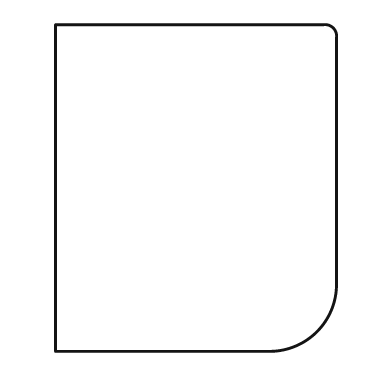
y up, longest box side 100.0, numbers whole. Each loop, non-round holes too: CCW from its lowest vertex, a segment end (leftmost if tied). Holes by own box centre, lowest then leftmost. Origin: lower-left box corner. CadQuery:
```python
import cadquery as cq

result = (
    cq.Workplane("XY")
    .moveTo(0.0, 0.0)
    .lineTo(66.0, 0.0)
    .threePointArc((80.0, 6.0), (86.0, 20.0))
    .lineTo(86.0, 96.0)
    .threePointArc((85.0, 99.0), (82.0, 100.0))
    .lineTo(0.0, 100.0)
    .close()
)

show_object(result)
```